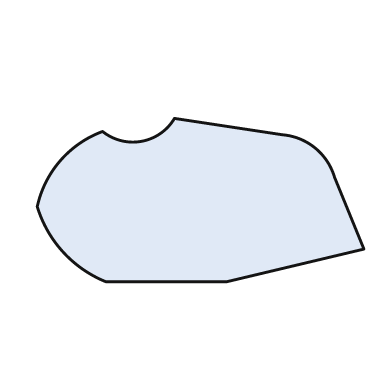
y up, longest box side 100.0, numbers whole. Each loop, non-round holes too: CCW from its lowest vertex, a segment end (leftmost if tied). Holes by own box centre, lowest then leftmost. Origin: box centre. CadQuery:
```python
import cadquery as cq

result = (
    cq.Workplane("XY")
    .moveTo(-29.0, -25.0)
    .lineTo(8.0, -25.0)
    .lineTo(50.0, -15.0)
    .lineTo(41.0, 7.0)
    .threePointArc((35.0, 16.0), (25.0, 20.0))
    .lineTo(-8.0, 25.0)
    .threePointArc((-18.0, 18.0), (-30.0, 21.0))
    .threePointArc((-43.0, 12.0), (-50.0, -2.0))
    .threePointArc((-42.0, -16.0), (-29.0, -25.0))
    .close()
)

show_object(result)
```